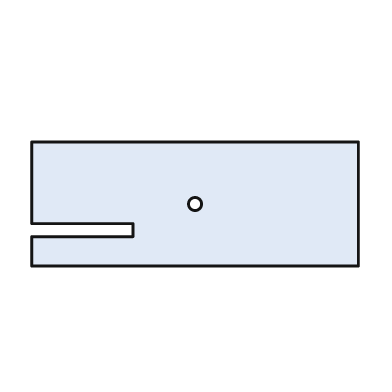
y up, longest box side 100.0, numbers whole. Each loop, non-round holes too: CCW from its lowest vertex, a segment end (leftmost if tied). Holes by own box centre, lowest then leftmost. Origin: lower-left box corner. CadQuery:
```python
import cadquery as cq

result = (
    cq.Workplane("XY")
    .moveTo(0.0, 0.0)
    .lineTo(100.0, 0.0)
    .lineTo(100.0, 38.0)
    .lineTo(0.0, 38.0)
    .lineTo(0.0, 13.0)
    .lineTo(31.0, 13.0)
    .lineTo(31.0, 9.0)
    .lineTo(0.0, 9.0)
    .close()
    .moveTo(50.0, 19.0)
    .circle(2.0)
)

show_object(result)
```